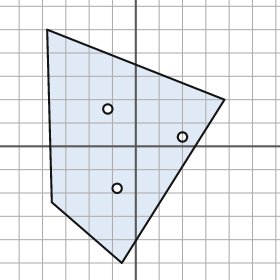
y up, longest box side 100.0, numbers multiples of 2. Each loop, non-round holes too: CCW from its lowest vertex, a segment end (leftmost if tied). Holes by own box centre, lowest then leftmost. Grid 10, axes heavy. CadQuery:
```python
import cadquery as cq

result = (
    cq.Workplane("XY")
    .moveTo(-6.0, -50.0)
    .lineTo(38.0, 20.0)
    .lineTo(-38.0, 50.0)
    .lineTo(-36.0, -24.0)
    .close()
    .moveTo(-8.0, -18.0)
    .circle(2.0)
    .moveTo(20.0, 4.0)
    .circle(2.0)
    .moveTo(-12.0, 16.0)
    .circle(2.0)
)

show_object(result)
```